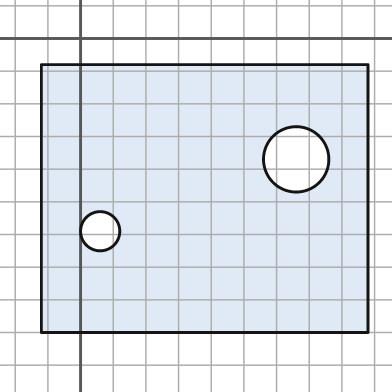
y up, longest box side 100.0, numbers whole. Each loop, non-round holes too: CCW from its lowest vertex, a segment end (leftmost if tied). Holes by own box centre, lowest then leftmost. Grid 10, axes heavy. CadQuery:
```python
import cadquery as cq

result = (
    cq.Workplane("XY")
    .moveTo(-12.0, -90.0)
    .lineTo(88.0, -90.0)
    .lineTo(88.0, -8.0)
    .lineTo(-12.0, -8.0)
    .close()
    .moveTo(6.0, -59.0)
    .circle(6.0)
    .moveTo(66.0, -37.0)
    .circle(10.0)
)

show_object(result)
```